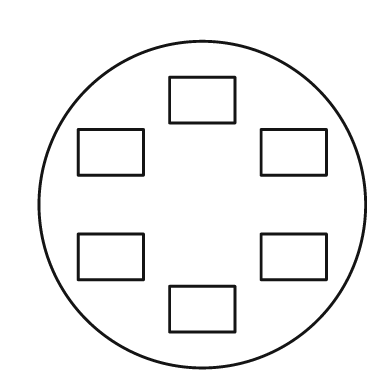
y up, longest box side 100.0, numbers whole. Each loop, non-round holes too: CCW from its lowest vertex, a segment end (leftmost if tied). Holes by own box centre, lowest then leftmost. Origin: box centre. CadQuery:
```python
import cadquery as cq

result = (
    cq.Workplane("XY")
    .moveTo(0.0, 0.0)
    .circle(50.0)
    .moveTo(-10.0, -39.0)
    .lineTo(10.0, -39.0)
    .lineTo(10.0, -25.0)
    .lineTo(-10.0, -25.0)
    .close()
    .moveTo(-38.0, -23.0)
    .lineTo(-18.0, -23.0)
    .lineTo(-18.0, -9.0)
    .lineTo(-38.0, -9.0)
    .close()
    .moveTo(18.0, -23.0)
    .lineTo(38.0, -23.0)
    .lineTo(38.0, -9.0)
    .lineTo(18.0, -9.0)
    .close()
    .moveTo(-38.0, 9.0)
    .lineTo(-18.0, 9.0)
    .lineTo(-18.0, 23.0)
    .lineTo(-38.0, 23.0)
    .close()
    .moveTo(18.0, 9.0)
    .lineTo(38.0, 9.0)
    .lineTo(38.0, 23.0)
    .lineTo(18.0, 23.0)
    .close()
    .moveTo(-10.0, 25.0)
    .lineTo(10.0, 25.0)
    .lineTo(10.0, 39.0)
    .lineTo(-10.0, 39.0)
    .close()
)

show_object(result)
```